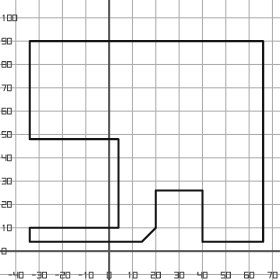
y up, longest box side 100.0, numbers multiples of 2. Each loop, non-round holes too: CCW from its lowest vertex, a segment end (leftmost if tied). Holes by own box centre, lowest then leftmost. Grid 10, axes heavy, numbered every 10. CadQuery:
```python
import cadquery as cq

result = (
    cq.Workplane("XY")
    .moveTo(-34.0, 4.0)
    .lineTo(14.0, 4.0)
    .lineTo(20.0, 10.0)
    .lineTo(20.0, 26.0)
    .lineTo(40.0, 26.0)
    .lineTo(40.0, 4.0)
    .lineTo(66.0, 4.0)
    .lineTo(66.0, 90.0)
    .lineTo(-34.0, 90.0)
    .lineTo(-34.0, 48.0)
    .lineTo(4.0, 48.0)
    .lineTo(4.0, 10.0)
    .lineTo(-34.0, 10.0)
    .close()
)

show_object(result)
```